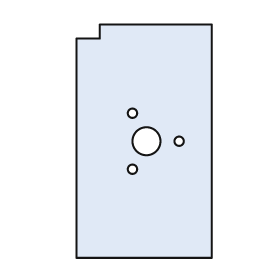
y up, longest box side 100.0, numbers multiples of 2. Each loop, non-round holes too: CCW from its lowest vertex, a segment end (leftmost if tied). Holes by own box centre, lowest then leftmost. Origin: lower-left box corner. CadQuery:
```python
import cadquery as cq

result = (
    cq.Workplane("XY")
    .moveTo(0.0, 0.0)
    .lineTo(58.0, 0.0)
    .lineTo(58.0, 100.0)
    .lineTo(10.0, 100.0)
    .lineTo(10.0, 94.0)
    .lineTo(0.0, 94.0)
    .close()
    .moveTo(24.0, 38.0)
    .circle(2.0)
    .moveTo(30.0, 50.0)
    .circle(6.0)
    .moveTo(44.0, 50.0)
    .circle(2.0)
    .moveTo(24.0, 62.0)
    .circle(2.0)
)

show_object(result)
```